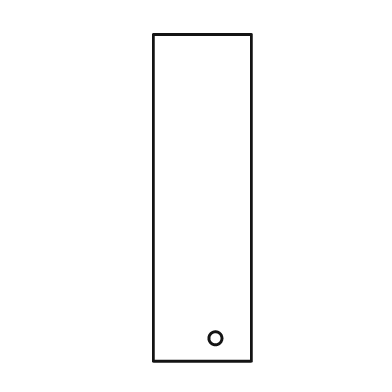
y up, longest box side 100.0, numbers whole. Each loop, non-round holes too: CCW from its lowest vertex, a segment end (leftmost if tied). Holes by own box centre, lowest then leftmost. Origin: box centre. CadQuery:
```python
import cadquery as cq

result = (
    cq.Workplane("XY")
    .moveTo(-15.0, -50.0)
    .lineTo(15.0, -50.0)
    .lineTo(15.0, 50.0)
    .lineTo(-15.0, 50.0)
    .close()
    .moveTo(4.0, -43.0)
    .circle(2.0)
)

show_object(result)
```